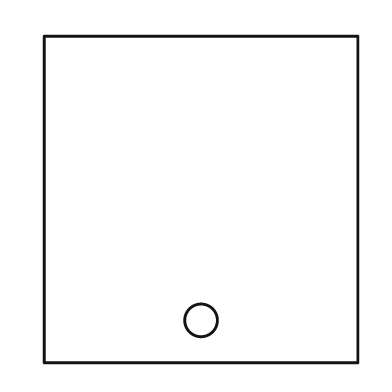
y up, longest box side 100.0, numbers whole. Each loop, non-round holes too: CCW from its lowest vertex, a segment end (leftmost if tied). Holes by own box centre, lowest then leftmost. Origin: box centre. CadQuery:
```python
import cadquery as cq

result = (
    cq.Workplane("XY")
    .moveTo(-48.0, -50.0)
    .lineTo(48.0, -50.0)
    .lineTo(48.0, 50.0)
    .lineTo(-48.0, 50.0)
    .close()
    .moveTo(0.0, -37.0)
    .circle(5.0)
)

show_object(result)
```